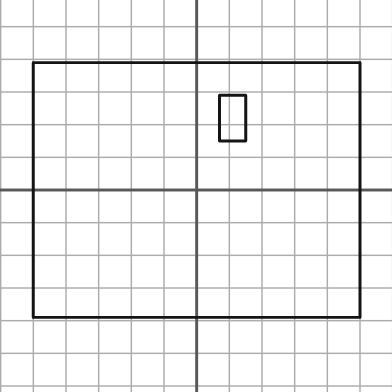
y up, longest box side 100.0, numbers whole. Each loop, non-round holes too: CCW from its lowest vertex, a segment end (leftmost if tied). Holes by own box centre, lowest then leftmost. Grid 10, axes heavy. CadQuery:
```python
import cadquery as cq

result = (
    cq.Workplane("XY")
    .moveTo(-50.0, -39.0)
    .lineTo(50.0, -39.0)
    .lineTo(50.0, 39.0)
    .lineTo(-50.0, 39.0)
    .close()
    .moveTo(7.0, 15.0)
    .lineTo(15.0, 15.0)
    .lineTo(15.0, 29.0)
    .lineTo(7.0, 29.0)
    .close()
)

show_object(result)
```